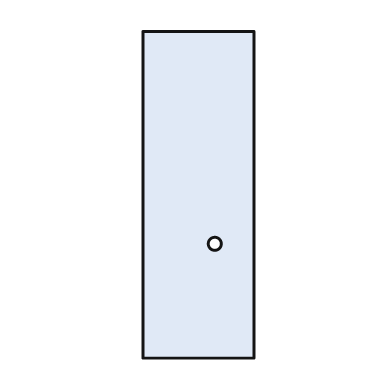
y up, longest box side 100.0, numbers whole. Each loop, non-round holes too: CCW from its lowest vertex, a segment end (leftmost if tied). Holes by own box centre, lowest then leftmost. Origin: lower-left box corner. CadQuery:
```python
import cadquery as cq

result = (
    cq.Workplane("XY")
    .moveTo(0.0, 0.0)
    .lineTo(34.0, 0.0)
    .lineTo(34.0, 100.0)
    .lineTo(0.0, 100.0)
    .close()
    .moveTo(22.0, 35.0)
    .circle(2.0)
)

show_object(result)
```